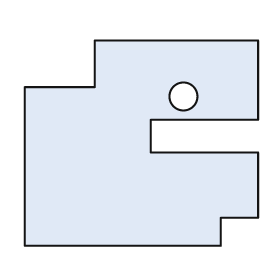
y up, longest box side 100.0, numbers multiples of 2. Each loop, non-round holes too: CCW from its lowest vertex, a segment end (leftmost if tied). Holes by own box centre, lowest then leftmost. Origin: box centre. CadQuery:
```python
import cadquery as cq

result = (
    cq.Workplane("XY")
    .moveTo(-50.0, -44.0)
    .lineTo(34.0, -44.0)
    .lineTo(34.0, -32.0)
    .lineTo(50.0, -32.0)
    .lineTo(50.0, -4.0)
    .lineTo(4.0, -4.0)
    .lineTo(4.0, 10.0)
    .lineTo(50.0, 10.0)
    .lineTo(50.0, 44.0)
    .lineTo(-20.0, 44.0)
    .lineTo(-20.0, 24.0)
    .lineTo(-50.0, 24.0)
    .close()
    .moveTo(18.0, 20.0)
    .circle(6.0)
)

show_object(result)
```